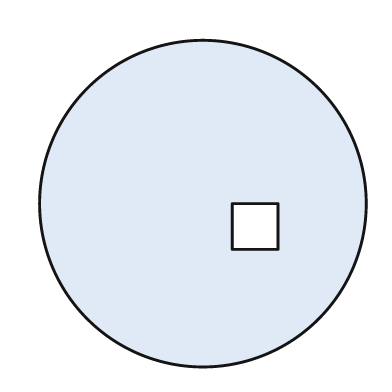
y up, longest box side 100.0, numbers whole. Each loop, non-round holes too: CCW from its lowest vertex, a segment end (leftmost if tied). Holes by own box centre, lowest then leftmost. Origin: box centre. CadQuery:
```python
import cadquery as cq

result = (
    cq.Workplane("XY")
    .moveTo(0.0, 0.0)
    .circle(50.0)
    .moveTo(9.0, -14.0)
    .lineTo(23.0, -14.0)
    .lineTo(23.0, 0.0)
    .lineTo(9.0, 0.0)
    .close()
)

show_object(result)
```